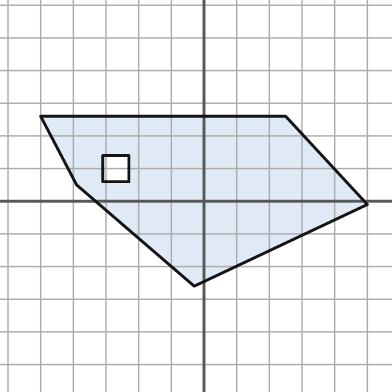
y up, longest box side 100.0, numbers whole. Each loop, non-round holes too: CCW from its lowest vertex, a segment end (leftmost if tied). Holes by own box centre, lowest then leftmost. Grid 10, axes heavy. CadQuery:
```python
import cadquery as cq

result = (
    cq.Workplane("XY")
    .moveTo(-3.0, -26.0)
    .lineTo(50.0, -1.0)
    .lineTo(25.0, 26.0)
    .lineTo(-50.0, 26.0)
    .lineTo(-39.0, 5.0)
    .close()
    .moveTo(-31.0, 6.0)
    .lineTo(-23.0, 6.0)
    .lineTo(-23.0, 14.0)
    .lineTo(-31.0, 14.0)
    .close()
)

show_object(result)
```